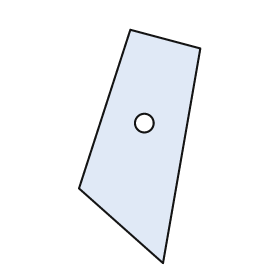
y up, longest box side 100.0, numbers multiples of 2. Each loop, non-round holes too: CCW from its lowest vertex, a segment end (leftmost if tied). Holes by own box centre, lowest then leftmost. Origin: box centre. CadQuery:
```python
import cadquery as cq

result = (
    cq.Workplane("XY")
    .moveTo(10.0, -50.0)
    .lineTo(26.0, 42.0)
    .lineTo(-4.0, 50.0)
    .lineTo(-26.0, -18.0)
    .close()
    .moveTo(2.0, 10.0)
    .circle(4.0)
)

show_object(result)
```